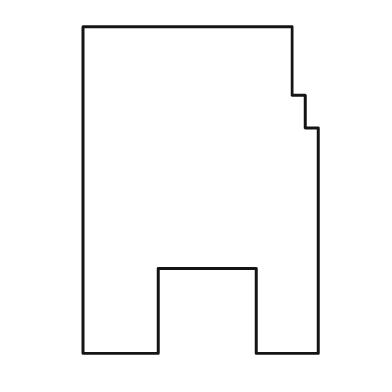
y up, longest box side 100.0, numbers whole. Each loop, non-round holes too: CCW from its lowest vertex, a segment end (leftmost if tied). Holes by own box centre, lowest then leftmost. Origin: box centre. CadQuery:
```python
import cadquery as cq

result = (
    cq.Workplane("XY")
    .moveTo(-36.0, -50.0)
    .lineTo(-13.0, -50.0)
    .lineTo(-13.0, -24.0)
    .lineTo(17.0, -24.0)
    .lineTo(17.0, -50.0)
    .lineTo(36.0, -50.0)
    .lineTo(36.0, 19.0)
    .lineTo(32.0, 19.0)
    .lineTo(32.0, 29.0)
    .lineTo(28.0, 29.0)
    .lineTo(28.0, 50.0)
    .lineTo(-36.0, 50.0)
    .close()
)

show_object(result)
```